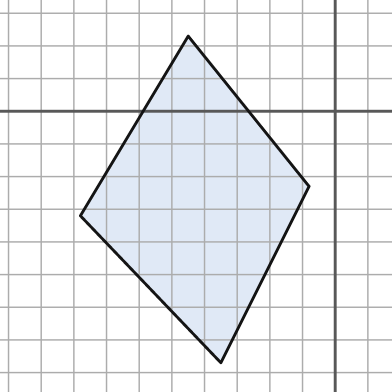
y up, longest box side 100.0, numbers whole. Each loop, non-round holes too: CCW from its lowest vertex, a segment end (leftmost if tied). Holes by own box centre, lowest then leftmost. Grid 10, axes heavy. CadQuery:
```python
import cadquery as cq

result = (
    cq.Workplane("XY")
    .moveTo(-35.0, -77.0)
    .lineTo(-8.0, -23.0)
    .lineTo(-45.0, 23.0)
    .lineTo(-78.0, -32.0)
    .close()
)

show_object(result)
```